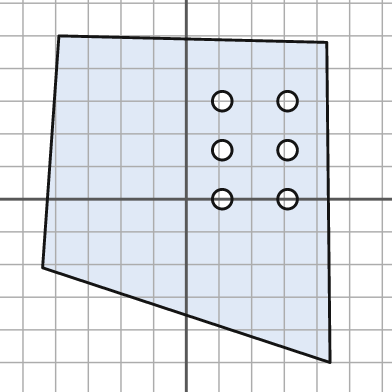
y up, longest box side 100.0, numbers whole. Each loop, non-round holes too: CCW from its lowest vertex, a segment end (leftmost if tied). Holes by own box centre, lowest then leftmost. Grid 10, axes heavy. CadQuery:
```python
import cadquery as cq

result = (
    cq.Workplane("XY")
    .moveTo(44.0, -50.0)
    .lineTo(43.0, 48.0)
    .lineTo(-39.0, 50.0)
    .lineTo(-44.0, -21.0)
    .close()
    .moveTo(11.0, 0.0)
    .circle(3.0)
    .moveTo(31.0, 0.0)
    .circle(3.0)
    .moveTo(11.0, 15.0)
    .circle(3.0)
    .moveTo(31.0, 15.0)
    .circle(3.0)
    .moveTo(11.0, 30.0)
    .circle(3.0)
    .moveTo(31.0, 30.0)
    .circle(3.0)
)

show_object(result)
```